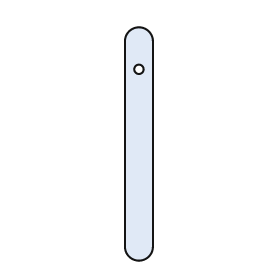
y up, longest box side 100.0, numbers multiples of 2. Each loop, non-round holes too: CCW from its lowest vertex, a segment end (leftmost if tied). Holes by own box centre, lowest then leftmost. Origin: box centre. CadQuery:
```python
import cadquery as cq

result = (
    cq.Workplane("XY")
    .moveTo(-6.0, -44.0)
    .threePointArc((0.0, -50.0), (6.0, -44.0))
    .lineTo(6.0, 44.0)
    .threePointArc((0.0, 50.0), (-6.0, 44.0))
    .close()
    .moveTo(0.0, 32.0)
    .circle(2.0)
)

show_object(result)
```